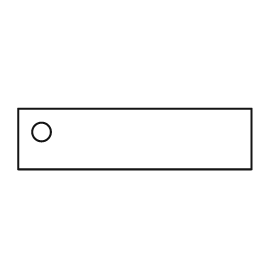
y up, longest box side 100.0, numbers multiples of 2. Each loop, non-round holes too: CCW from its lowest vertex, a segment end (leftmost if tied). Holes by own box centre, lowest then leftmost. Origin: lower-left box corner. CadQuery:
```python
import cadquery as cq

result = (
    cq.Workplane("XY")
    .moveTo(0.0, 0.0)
    .lineTo(100.0, 0.0)
    .lineTo(100.0, 26.0)
    .lineTo(0.0, 26.0)
    .close()
    .moveTo(10.0, 16.0)
    .circle(4.0)
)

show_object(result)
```